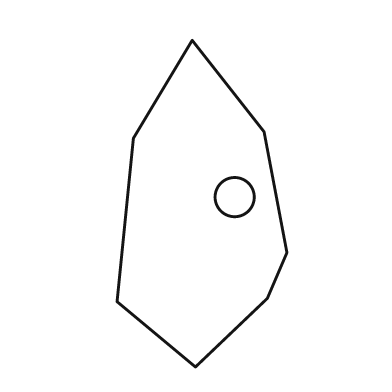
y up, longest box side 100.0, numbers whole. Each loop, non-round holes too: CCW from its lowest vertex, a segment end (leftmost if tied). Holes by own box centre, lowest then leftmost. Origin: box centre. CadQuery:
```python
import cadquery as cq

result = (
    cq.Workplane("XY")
    .moveTo(-2.0, -50.0)
    .lineTo(20.0, -29.0)
    .lineTo(26.0, -15.0)
    .lineTo(19.0, 22.0)
    .lineTo(-3.0, 50.0)
    .lineTo(-21.0, 20.0)
    .lineTo(-26.0, -30.0)
    .close()
    .moveTo(10.0, 2.0)
    .circle(6.0)
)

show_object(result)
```